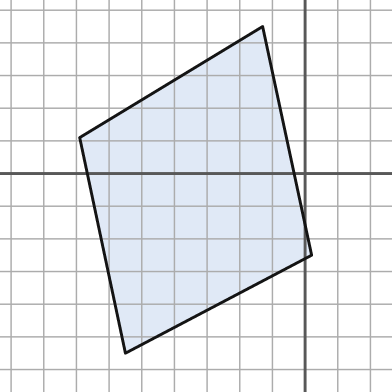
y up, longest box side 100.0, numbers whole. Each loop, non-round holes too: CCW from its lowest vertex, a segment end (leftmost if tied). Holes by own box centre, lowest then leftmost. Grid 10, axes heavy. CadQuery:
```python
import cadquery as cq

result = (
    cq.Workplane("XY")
    .moveTo(-55.0, -55.0)
    .lineTo(2.0, -25.0)
    .lineTo(-13.0, 45.0)
    .lineTo(-69.0, 11.0)
    .close()
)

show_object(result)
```